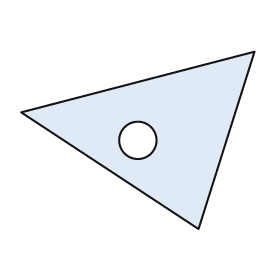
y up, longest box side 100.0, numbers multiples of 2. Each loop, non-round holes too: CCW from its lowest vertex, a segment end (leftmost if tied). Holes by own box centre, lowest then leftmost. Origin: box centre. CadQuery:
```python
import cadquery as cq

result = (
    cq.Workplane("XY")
    .moveTo(26.0, -38.0)
    .lineTo(50.0, 38.0)
    .lineTo(-50.0, 12.0)
    .close()
    .moveTo(0.0, 0.0)
    .circle(8.0)
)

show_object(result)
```